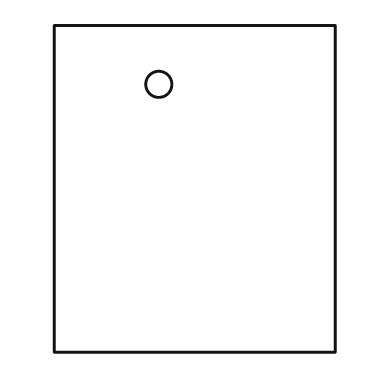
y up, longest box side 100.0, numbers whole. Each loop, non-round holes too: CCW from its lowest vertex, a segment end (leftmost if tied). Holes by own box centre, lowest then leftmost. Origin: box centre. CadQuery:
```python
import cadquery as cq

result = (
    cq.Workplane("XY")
    .moveTo(-43.0, -50.0)
    .lineTo(43.0, -50.0)
    .lineTo(43.0, 50.0)
    .lineTo(-43.0, 50.0)
    .close()
    .moveTo(-11.0, 32.0)
    .circle(4.0)
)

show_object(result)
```